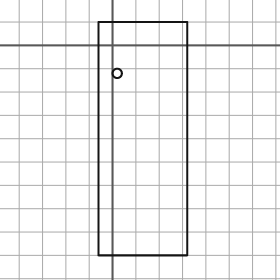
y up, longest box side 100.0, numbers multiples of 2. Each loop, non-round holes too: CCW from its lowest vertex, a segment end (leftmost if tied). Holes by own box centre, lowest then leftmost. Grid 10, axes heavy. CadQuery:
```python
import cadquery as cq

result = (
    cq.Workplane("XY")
    .moveTo(-6.0, -90.0)
    .lineTo(32.0, -90.0)
    .lineTo(32.0, 10.0)
    .lineTo(-6.0, 10.0)
    .close()
    .moveTo(2.0, -12.0)
    .circle(2.0)
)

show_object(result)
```